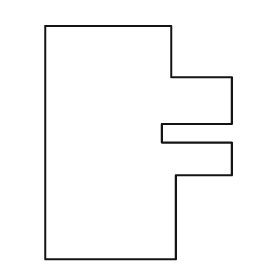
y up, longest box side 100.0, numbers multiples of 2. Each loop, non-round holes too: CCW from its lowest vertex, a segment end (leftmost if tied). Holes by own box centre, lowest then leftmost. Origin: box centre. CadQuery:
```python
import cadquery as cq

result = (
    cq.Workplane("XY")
    .moveTo(-40.0, -50.0)
    .lineTo(16.0, -50.0)
    .lineTo(16.0, -14.0)
    .lineTo(40.0, -14.0)
    .lineTo(40.0, 0.0)
    .lineTo(10.0, 0.0)
    .lineTo(10.0, 8.0)
    .lineTo(40.0, 8.0)
    .lineTo(40.0, 28.0)
    .lineTo(14.0, 28.0)
    .lineTo(14.0, 50.0)
    .lineTo(-40.0, 50.0)
    .close()
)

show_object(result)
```